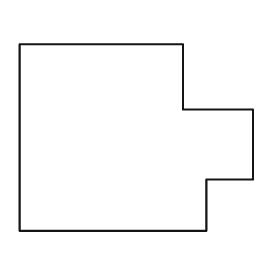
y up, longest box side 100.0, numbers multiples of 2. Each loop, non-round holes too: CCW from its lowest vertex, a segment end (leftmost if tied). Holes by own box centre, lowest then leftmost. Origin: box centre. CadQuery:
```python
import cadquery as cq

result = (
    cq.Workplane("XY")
    .moveTo(-50.0, -40.0)
    .lineTo(30.0, -40.0)
    .lineTo(30.0, -18.0)
    .lineTo(50.0, -18.0)
    .lineTo(50.0, 12.0)
    .lineTo(20.0, 12.0)
    .lineTo(20.0, 40.0)
    .lineTo(-50.0, 40.0)
    .close()
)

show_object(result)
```